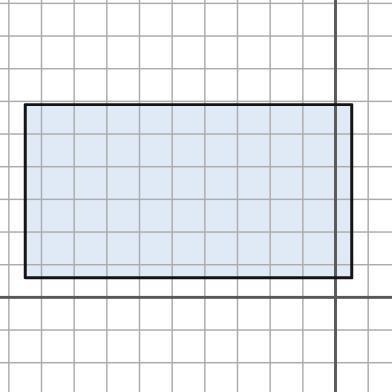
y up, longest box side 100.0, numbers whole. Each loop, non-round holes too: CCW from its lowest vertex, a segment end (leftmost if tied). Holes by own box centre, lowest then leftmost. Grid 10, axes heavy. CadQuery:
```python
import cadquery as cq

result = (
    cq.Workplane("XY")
    .moveTo(-95.0, 6.0)
    .lineTo(5.0, 6.0)
    .lineTo(5.0, 59.0)
    .lineTo(-95.0, 59.0)
    .close()
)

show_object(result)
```